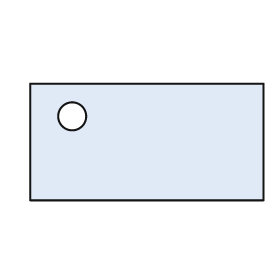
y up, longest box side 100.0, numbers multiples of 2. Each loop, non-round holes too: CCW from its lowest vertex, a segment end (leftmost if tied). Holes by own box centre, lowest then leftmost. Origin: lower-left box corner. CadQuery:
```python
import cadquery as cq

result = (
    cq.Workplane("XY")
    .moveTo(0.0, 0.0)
    .lineTo(100.0, 0.0)
    .lineTo(100.0, 50.0)
    .lineTo(0.0, 50.0)
    .close()
    .moveTo(18.0, 36.0)
    .circle(6.0)
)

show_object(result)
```